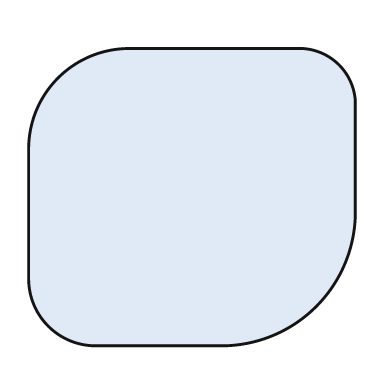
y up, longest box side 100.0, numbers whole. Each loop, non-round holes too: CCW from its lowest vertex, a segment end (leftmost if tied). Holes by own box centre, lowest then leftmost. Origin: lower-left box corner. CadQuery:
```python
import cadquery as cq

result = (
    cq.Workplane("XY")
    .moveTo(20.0, 0.0)
    .lineTo(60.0, 0.0)
    .threePointArc((88.0, 12.0), (100.0, 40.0))
    .lineTo(100.0, 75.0)
    .threePointArc((95.0, 86.0), (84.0, 91.0))
    .lineTo(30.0, 91.0)
    .threePointArc((9.0, 82.0), (0.0, 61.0))
    .lineTo(0.0, 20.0)
    .threePointArc((6.0, 6.0), (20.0, 0.0))
    .close()
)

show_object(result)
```